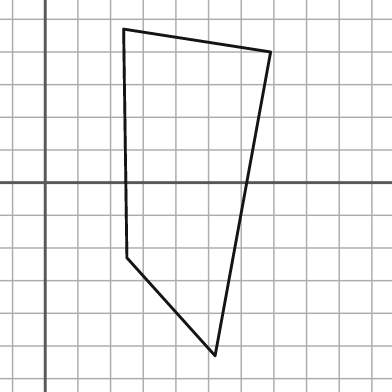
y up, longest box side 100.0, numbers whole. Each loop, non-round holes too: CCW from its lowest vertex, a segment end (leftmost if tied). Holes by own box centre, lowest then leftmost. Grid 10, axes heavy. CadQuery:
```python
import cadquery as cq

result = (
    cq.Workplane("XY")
    .moveTo(52.0, -53.0)
    .lineTo(69.0, 40.0)
    .lineTo(24.0, 47.0)
    .lineTo(25.0, -23.0)
    .close()
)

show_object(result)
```